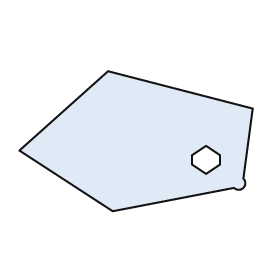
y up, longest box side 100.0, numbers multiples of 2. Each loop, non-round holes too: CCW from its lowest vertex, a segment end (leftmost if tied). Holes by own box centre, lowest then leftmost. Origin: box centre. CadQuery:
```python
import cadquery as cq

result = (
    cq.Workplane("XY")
    .moveTo(-10.0, -30.0)
    .lineTo(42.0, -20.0)
    .threePointArc((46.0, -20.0), (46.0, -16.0))
    .lineTo(50.0, 14.0)
    .lineTo(-12.0, 30.0)
    .lineTo(-50.0, -4.0)
    .close()
    .moveTo(30.0, -14.0)
    .lineTo(36.0, -10.0)
    .lineTo(36.0, -6.0)
    .lineTo(30.0, -2.0)
    .lineTo(24.0, -6.0)
    .lineTo(24.0, -10.0)
    .close()
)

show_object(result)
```